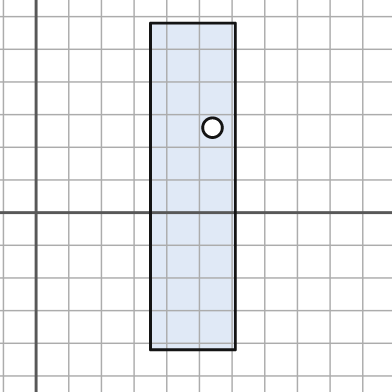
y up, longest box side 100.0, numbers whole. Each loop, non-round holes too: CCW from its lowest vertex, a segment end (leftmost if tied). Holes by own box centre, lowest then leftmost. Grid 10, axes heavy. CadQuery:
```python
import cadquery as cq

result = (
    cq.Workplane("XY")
    .moveTo(35.0, -42.0)
    .lineTo(61.0, -42.0)
    .lineTo(61.0, 58.0)
    .lineTo(35.0, 58.0)
    .close()
    .moveTo(54.0, 26.0)
    .circle(3.0)
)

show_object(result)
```